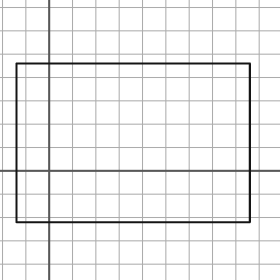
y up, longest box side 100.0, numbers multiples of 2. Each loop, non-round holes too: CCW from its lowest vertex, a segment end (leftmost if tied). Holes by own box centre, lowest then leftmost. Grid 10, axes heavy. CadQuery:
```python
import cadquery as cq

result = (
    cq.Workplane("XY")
    .moveTo(-14.0, -22.0)
    .lineTo(86.0, -22.0)
    .lineTo(86.0, 46.0)
    .lineTo(-14.0, 46.0)
    .close()
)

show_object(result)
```